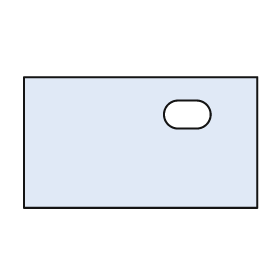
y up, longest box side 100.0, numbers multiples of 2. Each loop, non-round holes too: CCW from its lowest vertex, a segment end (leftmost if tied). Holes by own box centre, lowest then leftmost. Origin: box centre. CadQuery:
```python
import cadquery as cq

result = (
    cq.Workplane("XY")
    .moveTo(-50.0, -28.0)
    .lineTo(50.0, -28.0)
    .lineTo(50.0, 28.0)
    .lineTo(-50.0, 28.0)
    .close()
    .moveTo(16.0, 6.0)
    .lineTo(24.0, 6.0)
    .threePointArc((30.0, 12.0), (24.0, 18.0))
    .lineTo(16.0, 18.0)
    .threePointArc((10.0, 12.0), (16.0, 6.0))
    .close()
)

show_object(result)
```